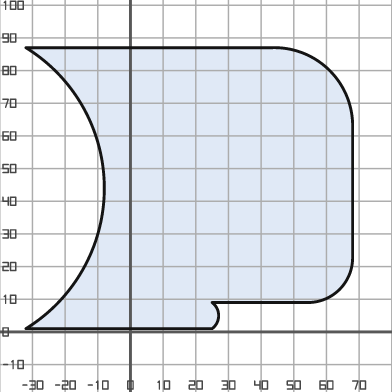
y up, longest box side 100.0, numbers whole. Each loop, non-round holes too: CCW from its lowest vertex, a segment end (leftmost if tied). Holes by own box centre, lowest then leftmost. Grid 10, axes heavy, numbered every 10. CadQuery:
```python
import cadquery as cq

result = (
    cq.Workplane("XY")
    .moveTo(-32.0, 1.0)
    .lineTo(25.0, 1.0)
    .threePointArc((27.0, 5.0), (25.0, 9.0))
    .lineTo(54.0, 9.0)
    .threePointArc((64.0, 13.0), (68.0, 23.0))
    .lineTo(68.0, 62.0)
    .threePointArc((61.0, 80.0), (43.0, 87.0))
    .lineTo(-32.0, 87.0)
    .threePointArc((-8.0, 44.0), (-32.0, 1.0))
    .close()
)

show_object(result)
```